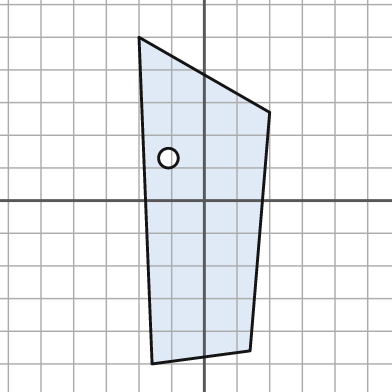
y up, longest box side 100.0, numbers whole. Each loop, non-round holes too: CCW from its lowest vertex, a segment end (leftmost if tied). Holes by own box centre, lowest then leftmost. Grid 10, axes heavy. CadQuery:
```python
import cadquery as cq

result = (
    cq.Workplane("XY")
    .moveTo(-16.0, -50.0)
    .lineTo(14.0, -46.0)
    .lineTo(20.0, 27.0)
    .lineTo(-20.0, 50.0)
    .close()
    .moveTo(-11.0, 13.0)
    .circle(3.0)
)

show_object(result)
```